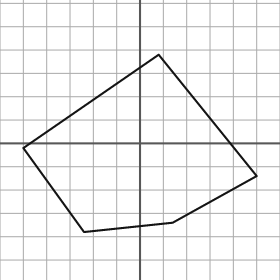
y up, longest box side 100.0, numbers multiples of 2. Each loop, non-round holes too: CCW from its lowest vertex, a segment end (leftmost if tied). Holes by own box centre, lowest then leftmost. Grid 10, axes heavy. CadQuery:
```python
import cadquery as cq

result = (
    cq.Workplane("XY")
    .moveTo(-24.0, -38.0)
    .lineTo(14.0, -34.0)
    .lineTo(50.0, -14.0)
    .lineTo(8.0, 38.0)
    .lineTo(-50.0, -2.0)
    .close()
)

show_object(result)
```